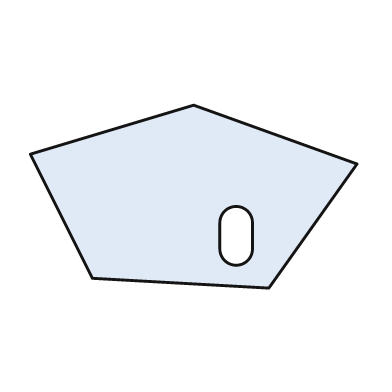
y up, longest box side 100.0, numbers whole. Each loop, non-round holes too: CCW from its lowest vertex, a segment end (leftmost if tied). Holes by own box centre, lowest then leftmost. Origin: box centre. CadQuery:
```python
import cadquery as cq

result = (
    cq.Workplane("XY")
    .moveTo(23.0, -28.0)
    .lineTo(50.0, 10.0)
    .lineTo(0.0, 28.0)
    .lineTo(-50.0, 13.0)
    .lineTo(-31.0, -25.0)
    .close()
    .moveTo(8.0, -16.0)
    .threePointArc((13.0, -21.0), (18.0, -16.0))
    .lineTo(18.0, -8.0)
    .threePointArc((13.0, -3.0), (8.0, -8.0))
    .close()
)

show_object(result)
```